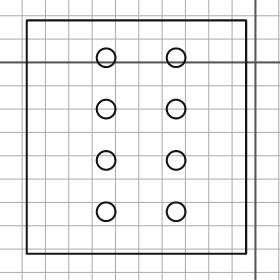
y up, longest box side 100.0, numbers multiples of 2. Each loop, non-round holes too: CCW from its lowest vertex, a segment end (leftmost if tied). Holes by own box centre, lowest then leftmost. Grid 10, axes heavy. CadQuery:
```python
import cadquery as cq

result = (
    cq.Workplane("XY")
    .moveTo(-98.0, -82.0)
    .lineTo(-4.0, -82.0)
    .lineTo(-4.0, 18.0)
    .lineTo(-98.0, 18.0)
    .close()
    .moveTo(-64.0, -64.0)
    .circle(4.0)
    .moveTo(-34.0, -64.0)
    .circle(4.0)
    .moveTo(-64.0, -42.0)
    .circle(4.0)
    .moveTo(-34.0, -42.0)
    .circle(4.0)
    .moveTo(-64.0, -20.0)
    .circle(4.0)
    .moveTo(-34.0, -20.0)
    .circle(4.0)
    .moveTo(-64.0, 2.0)
    .circle(4.0)
    .moveTo(-34.0, 2.0)
    .circle(4.0)
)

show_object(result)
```